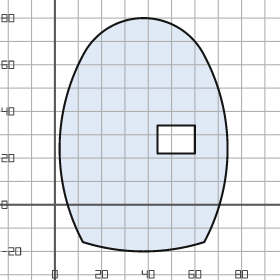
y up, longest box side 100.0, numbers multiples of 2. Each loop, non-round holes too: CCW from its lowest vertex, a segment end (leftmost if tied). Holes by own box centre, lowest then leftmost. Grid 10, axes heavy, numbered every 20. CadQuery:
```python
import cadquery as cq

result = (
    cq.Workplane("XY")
    .moveTo(12.0, -16.0)
    .threePointArc((38.0, -20.0), (64.0, -16.0))
    .threePointArc((74.0, 24.0), (64.0, 64.0))
    .threePointArc((38.0, 80.0), (12.0, 64.0))
    .threePointArc((2.0, 24.0), (12.0, -16.0))
    .close()
    .moveTo(44.0, 22.0)
    .lineTo(60.0, 22.0)
    .lineTo(60.0, 34.0)
    .lineTo(44.0, 34.0)
    .close()
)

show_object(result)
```